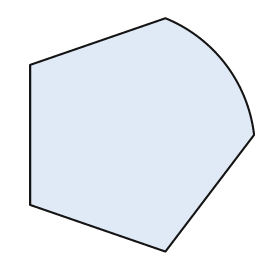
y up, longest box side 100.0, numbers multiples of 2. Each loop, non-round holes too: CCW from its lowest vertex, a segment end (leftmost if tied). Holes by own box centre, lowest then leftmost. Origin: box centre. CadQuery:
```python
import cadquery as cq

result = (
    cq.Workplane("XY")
    .moveTo(10.0, -50.0)
    .lineTo(48.0, 0.0)
    .threePointArc((36.0, 30.0), (10.0, 50.0))
    .lineTo(-48.0, 30.0)
    .lineTo(-48.0, -30.0)
    .close()
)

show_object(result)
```